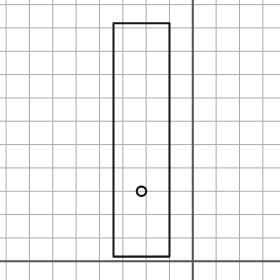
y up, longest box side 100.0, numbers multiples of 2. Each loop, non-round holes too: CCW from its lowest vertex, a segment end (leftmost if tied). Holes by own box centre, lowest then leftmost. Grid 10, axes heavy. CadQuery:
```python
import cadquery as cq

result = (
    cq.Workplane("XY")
    .moveTo(-34.0, 2.0)
    .lineTo(-10.0, 2.0)
    .lineTo(-10.0, 102.0)
    .lineTo(-34.0, 102.0)
    .close()
    .moveTo(-22.0, 30.0)
    .circle(2.0)
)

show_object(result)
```